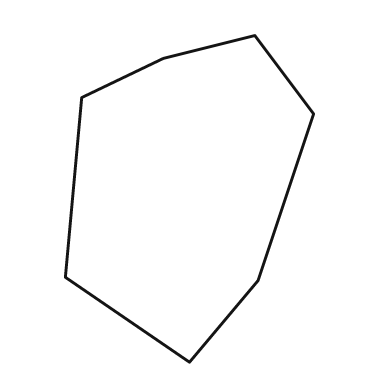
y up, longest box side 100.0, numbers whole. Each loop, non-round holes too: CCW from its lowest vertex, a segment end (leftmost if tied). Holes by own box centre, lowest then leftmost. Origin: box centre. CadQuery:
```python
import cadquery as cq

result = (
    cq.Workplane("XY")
    .moveTo(0.0, -50.0)
    .lineTo(21.0, -25.0)
    .lineTo(38.0, 26.0)
    .lineTo(20.0, 50.0)
    .lineTo(-8.0, 43.0)
    .lineTo(-33.0, 31.0)
    .lineTo(-38.0, -24.0)
    .close()
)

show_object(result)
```